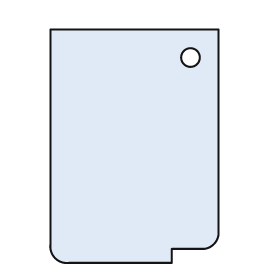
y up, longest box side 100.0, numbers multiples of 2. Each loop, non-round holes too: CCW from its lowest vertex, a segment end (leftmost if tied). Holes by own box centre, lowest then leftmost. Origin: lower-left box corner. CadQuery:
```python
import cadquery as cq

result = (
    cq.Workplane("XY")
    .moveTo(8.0, 0.0)
    .lineTo(52.0, 0.0)
    .lineTo(52.0, 6.0)
    .lineTo(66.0, 6.0)
    .threePointArc((70.0, 8.0), (72.0, 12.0))
    .lineTo(72.0, 100.0)
    .lineTo(0.0, 100.0)
    .lineTo(0.0, 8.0)
    .threePointArc((2.0, 2.0), (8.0, 0.0))
    .close()
    .moveTo(60.0, 88.0)
    .circle(4.0)
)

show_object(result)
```